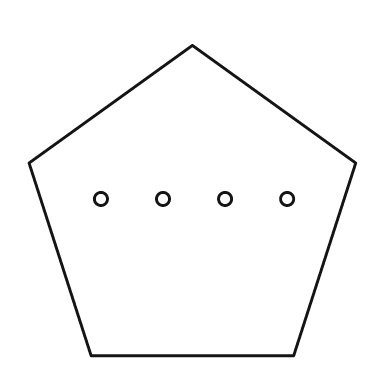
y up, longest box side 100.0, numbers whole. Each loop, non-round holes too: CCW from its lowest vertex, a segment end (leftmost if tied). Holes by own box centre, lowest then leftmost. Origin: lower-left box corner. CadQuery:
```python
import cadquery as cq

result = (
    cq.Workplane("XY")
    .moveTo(19.0, 0.0)
    .lineTo(81.0, 0.0)
    .lineTo(100.0, 59.0)
    .lineTo(50.0, 95.0)
    .lineTo(0.0, 59.0)
    .close()
    .moveTo(22.0, 48.0)
    .circle(2.0)
    .moveTo(41.0, 48.0)
    .circle(2.0)
    .moveTo(60.0, 48.0)
    .circle(2.0)
    .moveTo(79.0, 48.0)
    .circle(2.0)
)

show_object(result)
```